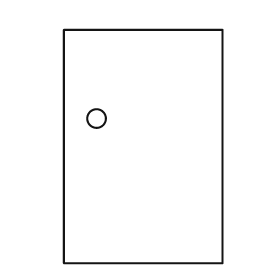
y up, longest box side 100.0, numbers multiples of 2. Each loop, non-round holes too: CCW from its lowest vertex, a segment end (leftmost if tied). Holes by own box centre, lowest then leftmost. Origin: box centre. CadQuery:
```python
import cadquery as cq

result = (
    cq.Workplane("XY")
    .moveTo(-34.0, -50.0)
    .lineTo(34.0, -50.0)
    .lineTo(34.0, 50.0)
    .lineTo(-34.0, 50.0)
    .close()
    .moveTo(-20.0, 12.0)
    .circle(4.0)
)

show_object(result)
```